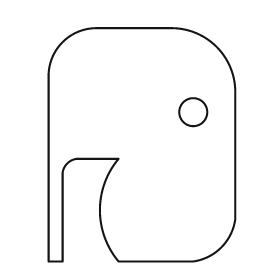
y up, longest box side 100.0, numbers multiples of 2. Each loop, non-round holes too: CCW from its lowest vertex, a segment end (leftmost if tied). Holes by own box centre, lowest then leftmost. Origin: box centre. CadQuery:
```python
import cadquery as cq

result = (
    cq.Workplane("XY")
    .moveTo(-40.0, -50.0)
    .lineTo(-34.0, -50.0)
    .lineTo(-34.0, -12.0)
    .threePointArc((-32.0, -8.0), (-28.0, -6.0))
    .lineTo(-10.0, -6.0)
    .threePointArc((-18.0, -28.0), (-10.0, -50.0))
    .lineTo(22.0, -50.0)
    .threePointArc((34.0, -44.0), (40.0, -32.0))
    .lineTo(40.0, 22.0)
    .threePointArc((32.0, 42.0), (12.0, 50.0))
    .lineTo(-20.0, 50.0)
    .threePointArc((-34.0, 44.0), (-40.0, 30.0))
    .close()
    .moveTo(22.0, 14.0)
    .circle(6.0)
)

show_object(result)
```